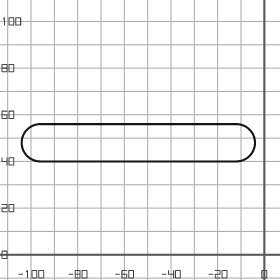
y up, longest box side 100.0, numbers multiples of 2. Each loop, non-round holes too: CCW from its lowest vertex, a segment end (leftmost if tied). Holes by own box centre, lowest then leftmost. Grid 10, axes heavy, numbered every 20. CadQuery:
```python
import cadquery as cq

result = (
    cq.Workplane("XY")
    .moveTo(-96.0, 40.0)
    .lineTo(-12.0, 40.0)
    .threePointArc((-4.0, 48.0), (-12.0, 56.0))
    .lineTo(-96.0, 56.0)
    .threePointArc((-104.0, 48.0), (-96.0, 40.0))
    .close()
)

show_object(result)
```